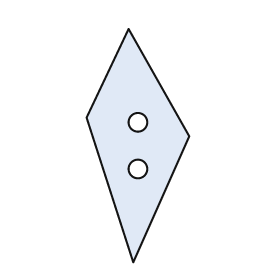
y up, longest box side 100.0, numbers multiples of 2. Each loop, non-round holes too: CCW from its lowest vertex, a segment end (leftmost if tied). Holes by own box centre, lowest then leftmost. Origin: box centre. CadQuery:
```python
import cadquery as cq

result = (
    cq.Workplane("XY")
    .moveTo(-2.0, -50.0)
    .lineTo(22.0, 4.0)
    .lineTo(-4.0, 50.0)
    .lineTo(-22.0, 12.0)
    .close()
    .moveTo(0.0, -10.0)
    .circle(4.0)
    .moveTo(0.0, 10.0)
    .circle(4.0)
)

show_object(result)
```